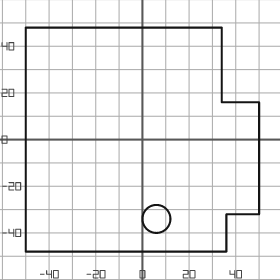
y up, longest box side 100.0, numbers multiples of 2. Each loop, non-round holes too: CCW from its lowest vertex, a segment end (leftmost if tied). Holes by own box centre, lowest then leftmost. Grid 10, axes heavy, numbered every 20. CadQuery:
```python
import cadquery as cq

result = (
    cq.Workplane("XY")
    .moveTo(-50.0, -48.0)
    .lineTo(36.0, -48.0)
    .lineTo(36.0, -32.0)
    .lineTo(50.0, -32.0)
    .lineTo(50.0, 16.0)
    .lineTo(34.0, 16.0)
    .lineTo(34.0, 48.0)
    .lineTo(-50.0, 48.0)
    .close()
    .moveTo(6.0, -34.0)
    .circle(6.0)
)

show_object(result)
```